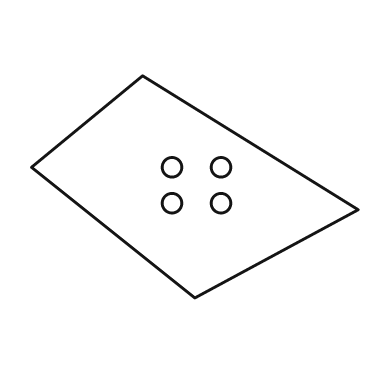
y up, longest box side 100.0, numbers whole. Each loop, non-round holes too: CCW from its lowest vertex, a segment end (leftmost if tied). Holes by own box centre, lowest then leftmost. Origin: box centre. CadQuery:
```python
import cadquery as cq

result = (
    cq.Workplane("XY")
    .moveTo(0.0, -34.0)
    .lineTo(50.0, -7.0)
    .lineTo(-16.0, 34.0)
    .lineTo(-50.0, 6.0)
    .close()
    .moveTo(-7.0, -5.0)
    .circle(3.0)
    .moveTo(8.0, -5.0)
    .circle(3.0)
    .moveTo(-7.0, 6.0)
    .circle(3.0)
    .moveTo(8.0, 6.0)
    .circle(3.0)
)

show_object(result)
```